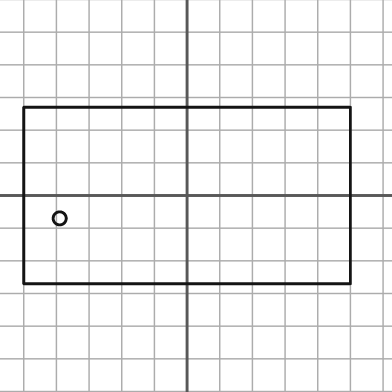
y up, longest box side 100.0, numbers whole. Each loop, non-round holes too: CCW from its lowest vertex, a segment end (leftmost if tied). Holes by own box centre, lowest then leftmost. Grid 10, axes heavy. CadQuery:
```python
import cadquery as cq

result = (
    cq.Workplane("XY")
    .moveTo(-50.0, -27.0)
    .lineTo(50.0, -27.0)
    .lineTo(50.0, 27.0)
    .lineTo(-50.0, 27.0)
    .close()
    .moveTo(-39.0, -7.0)
    .circle(2.0)
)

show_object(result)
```